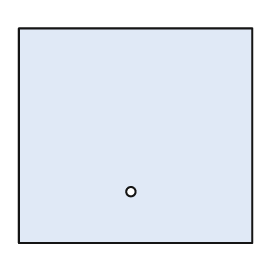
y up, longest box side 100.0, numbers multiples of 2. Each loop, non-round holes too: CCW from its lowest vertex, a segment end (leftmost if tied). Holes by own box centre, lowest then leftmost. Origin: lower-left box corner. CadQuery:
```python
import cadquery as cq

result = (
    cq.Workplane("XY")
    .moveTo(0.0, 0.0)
    .lineTo(100.0, 0.0)
    .lineTo(100.0, 92.0)
    .lineTo(0.0, 92.0)
    .close()
    .moveTo(48.0, 22.0)
    .circle(2.0)
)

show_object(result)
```